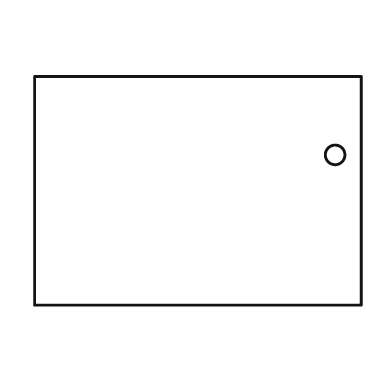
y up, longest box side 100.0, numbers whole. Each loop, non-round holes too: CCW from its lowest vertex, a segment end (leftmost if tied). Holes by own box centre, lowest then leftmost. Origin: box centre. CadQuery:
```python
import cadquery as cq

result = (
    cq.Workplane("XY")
    .moveTo(-50.0, -35.0)
    .lineTo(50.0, -35.0)
    .lineTo(50.0, 35.0)
    .lineTo(-50.0, 35.0)
    .close()
    .moveTo(42.0, 11.0)
    .circle(3.0)
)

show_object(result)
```